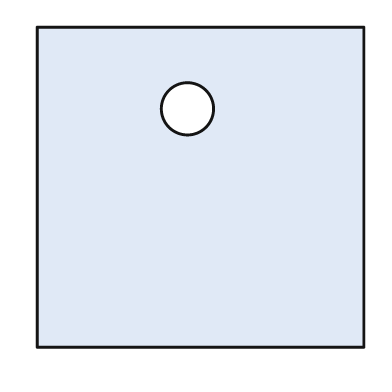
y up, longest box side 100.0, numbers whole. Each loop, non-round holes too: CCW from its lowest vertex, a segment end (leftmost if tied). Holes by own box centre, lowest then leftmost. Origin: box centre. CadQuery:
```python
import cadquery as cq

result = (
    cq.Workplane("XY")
    .moveTo(-50.0, -49.0)
    .lineTo(50.0, -49.0)
    .lineTo(50.0, 49.0)
    .lineTo(-50.0, 49.0)
    .close()
    .moveTo(-4.0, 24.0)
    .circle(8.0)
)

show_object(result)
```